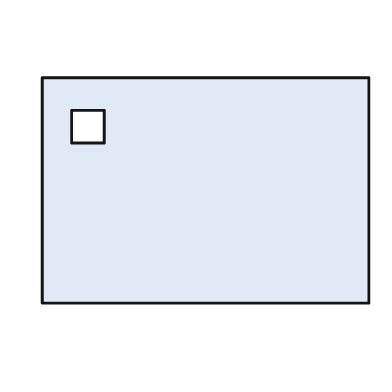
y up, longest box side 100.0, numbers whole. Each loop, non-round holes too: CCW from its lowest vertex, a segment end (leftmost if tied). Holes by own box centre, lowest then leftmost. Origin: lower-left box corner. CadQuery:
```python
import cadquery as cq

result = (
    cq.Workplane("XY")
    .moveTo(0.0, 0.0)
    .lineTo(100.0, 0.0)
    .lineTo(100.0, 69.0)
    .lineTo(0.0, 69.0)
    .close()
    .moveTo(9.0, 49.0)
    .lineTo(19.0, 49.0)
    .lineTo(19.0, 59.0)
    .lineTo(9.0, 59.0)
    .close()
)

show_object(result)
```